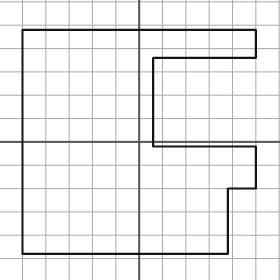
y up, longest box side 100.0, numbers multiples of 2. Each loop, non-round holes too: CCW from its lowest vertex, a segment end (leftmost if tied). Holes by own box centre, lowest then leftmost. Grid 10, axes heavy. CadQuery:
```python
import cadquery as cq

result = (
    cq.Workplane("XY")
    .moveTo(-50.0, -48.0)
    .lineTo(38.0, -48.0)
    .lineTo(38.0, -20.0)
    .lineTo(50.0, -20.0)
    .lineTo(50.0, -2.0)
    .lineTo(6.0, -2.0)
    .lineTo(6.0, 36.0)
    .lineTo(50.0, 36.0)
    .lineTo(50.0, 48.0)
    .lineTo(-50.0, 48.0)
    .close()
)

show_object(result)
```